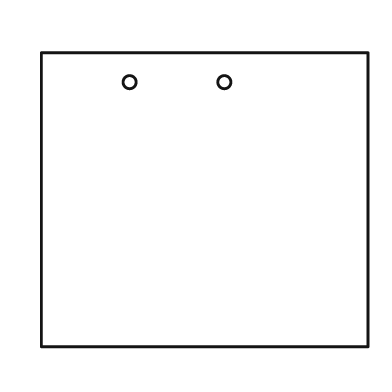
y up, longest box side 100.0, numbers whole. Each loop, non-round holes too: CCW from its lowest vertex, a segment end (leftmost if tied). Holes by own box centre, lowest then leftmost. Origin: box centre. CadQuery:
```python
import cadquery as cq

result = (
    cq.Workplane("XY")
    .moveTo(-50.0, -45.0)
    .lineTo(50.0, -45.0)
    .lineTo(50.0, 45.0)
    .lineTo(-50.0, 45.0)
    .close()
    .moveTo(-23.0, 36.0)
    .circle(2.0)
    .moveTo(6.0, 36.0)
    .circle(2.0)
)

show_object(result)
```